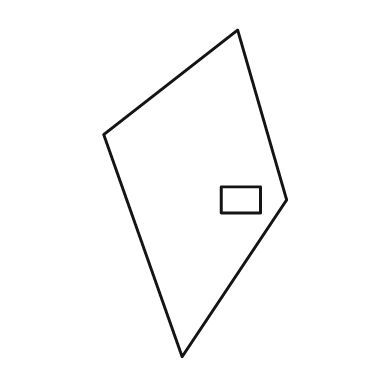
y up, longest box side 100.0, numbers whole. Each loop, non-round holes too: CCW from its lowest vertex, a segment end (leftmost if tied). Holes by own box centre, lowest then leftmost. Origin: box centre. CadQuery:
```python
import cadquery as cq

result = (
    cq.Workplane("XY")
    .moveTo(-4.0, -50.0)
    .lineTo(28.0, -2.0)
    .lineTo(13.0, 50.0)
    .lineTo(-28.0, 18.0)
    .close()
    .moveTo(8.0, -6.0)
    .lineTo(20.0, -6.0)
    .lineTo(20.0, 2.0)
    .lineTo(8.0, 2.0)
    .close()
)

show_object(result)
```